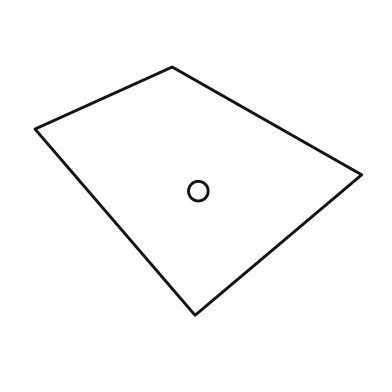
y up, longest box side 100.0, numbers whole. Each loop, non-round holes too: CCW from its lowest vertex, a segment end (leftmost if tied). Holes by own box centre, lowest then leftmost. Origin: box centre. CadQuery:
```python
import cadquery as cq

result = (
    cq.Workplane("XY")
    .moveTo(-1.0, -38.0)
    .lineTo(50.0, 5.0)
    .lineTo(-8.0, 38.0)
    .lineTo(-50.0, 19.0)
    .close()
    .moveTo(0.0, 0.0)
    .circle(3.0)
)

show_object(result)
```